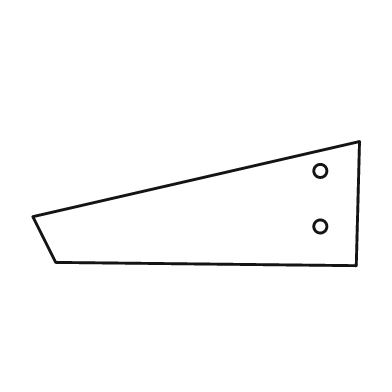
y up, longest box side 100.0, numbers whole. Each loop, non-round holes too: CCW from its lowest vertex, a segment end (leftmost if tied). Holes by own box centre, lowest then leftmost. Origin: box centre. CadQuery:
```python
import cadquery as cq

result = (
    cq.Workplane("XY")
    .moveTo(49.0, -19.0)
    .lineTo(50.0, 19.0)
    .lineTo(-50.0, -4.0)
    .lineTo(-43.0, -18.0)
    .close()
    .moveTo(38.0, -7.0)
    .circle(2.0)
    .moveTo(38.0, 10.0)
    .circle(2.0)
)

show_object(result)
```